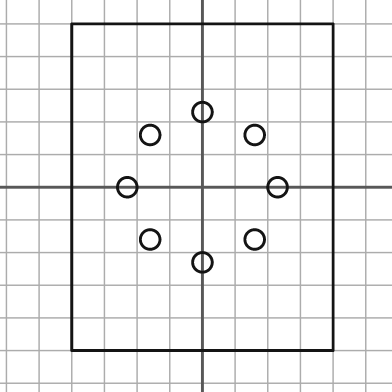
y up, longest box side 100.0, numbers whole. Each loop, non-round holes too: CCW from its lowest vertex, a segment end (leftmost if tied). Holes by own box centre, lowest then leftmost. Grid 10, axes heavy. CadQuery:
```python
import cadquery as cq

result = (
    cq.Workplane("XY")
    .moveTo(-40.0, -50.0)
    .lineTo(40.0, -50.0)
    .lineTo(40.0, 50.0)
    .lineTo(-40.0, 50.0)
    .close()
    .moveTo(0.0, -23.0)
    .circle(3.0)
    .moveTo(-16.0, -16.0)
    .circle(3.0)
    .moveTo(16.0, -16.0)
    .circle(3.0)
    .moveTo(-23.0, 0.0)
    .circle(3.0)
    .moveTo(23.0, 0.0)
    .circle(3.0)
    .moveTo(-16.0, 16.0)
    .circle(3.0)
    .moveTo(16.0, 16.0)
    .circle(3.0)
    .moveTo(0.0, 23.0)
    .circle(3.0)
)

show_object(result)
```